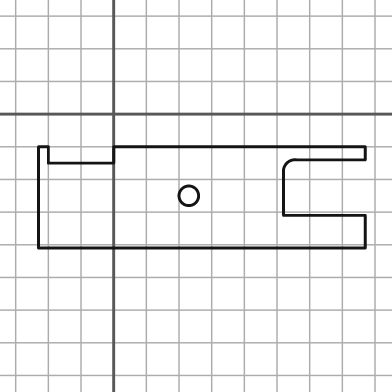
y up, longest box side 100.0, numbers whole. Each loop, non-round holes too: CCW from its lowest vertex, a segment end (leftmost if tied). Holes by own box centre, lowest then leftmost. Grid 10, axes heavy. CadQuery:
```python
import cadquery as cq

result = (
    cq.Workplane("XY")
    .moveTo(-23.0, -41.0)
    .lineTo(77.0, -41.0)
    .lineTo(77.0, -31.0)
    .lineTo(52.0, -31.0)
    .lineTo(52.0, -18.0)
    .threePointArc((53.0, -15.0), (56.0, -14.0))
    .lineTo(77.0, -14.0)
    .lineTo(77.0, -10.0)
    .lineTo(0.0, -10.0)
    .lineTo(0.0, -15.0)
    .lineTo(-20.0, -15.0)
    .lineTo(-20.0, -10.0)
    .lineTo(-23.0, -10.0)
    .close()
    .moveTo(23.0, -25.0)
    .circle(3.0)
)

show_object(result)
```